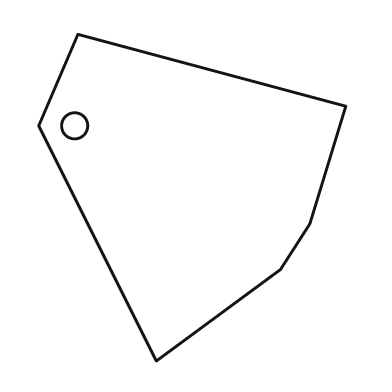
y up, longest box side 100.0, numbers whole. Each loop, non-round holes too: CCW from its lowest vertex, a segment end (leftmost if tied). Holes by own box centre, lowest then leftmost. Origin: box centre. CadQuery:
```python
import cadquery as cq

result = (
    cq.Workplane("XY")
    .moveTo(-11.0, -50.0)
    .lineTo(27.0, -22.0)
    .lineTo(36.0, -8.0)
    .lineTo(47.0, 28.0)
    .lineTo(-35.0, 50.0)
    .lineTo(-47.0, 22.0)
    .close()
    .moveTo(-36.0, 22.0)
    .circle(4.0)
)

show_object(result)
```